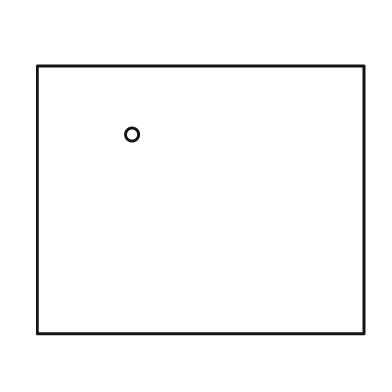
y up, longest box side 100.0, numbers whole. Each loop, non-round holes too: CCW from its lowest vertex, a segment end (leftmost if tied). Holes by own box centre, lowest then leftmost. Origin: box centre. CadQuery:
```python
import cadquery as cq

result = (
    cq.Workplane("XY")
    .moveTo(-50.0, -41.0)
    .lineTo(50.0, -41.0)
    .lineTo(50.0, 41.0)
    .lineTo(-50.0, 41.0)
    .close()
    .moveTo(-21.0, 20.0)
    .circle(2.0)
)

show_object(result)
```